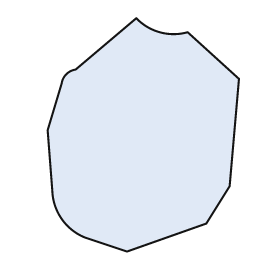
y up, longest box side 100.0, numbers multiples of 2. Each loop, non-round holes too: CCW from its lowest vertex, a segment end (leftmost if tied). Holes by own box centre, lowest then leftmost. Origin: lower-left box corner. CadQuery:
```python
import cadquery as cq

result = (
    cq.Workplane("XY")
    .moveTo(34.0, 0.0)
    .lineTo(68.0, 12.0)
    .lineTo(78.0, 28.0)
    .lineTo(82.0, 74.0)
    .lineTo(60.0, 94.0)
    .threePointArc((48.0, 94.0), (38.0, 100.0))
    .lineTo(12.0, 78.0)
    .threePointArc((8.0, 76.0), (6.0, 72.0))
    .lineTo(0.0, 52.0)
    .lineTo(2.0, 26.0)
    .threePointArc((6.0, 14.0), (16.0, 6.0))
    .close()
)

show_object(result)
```